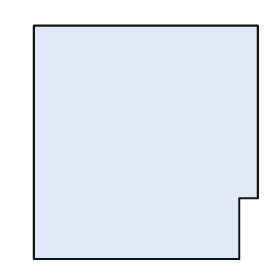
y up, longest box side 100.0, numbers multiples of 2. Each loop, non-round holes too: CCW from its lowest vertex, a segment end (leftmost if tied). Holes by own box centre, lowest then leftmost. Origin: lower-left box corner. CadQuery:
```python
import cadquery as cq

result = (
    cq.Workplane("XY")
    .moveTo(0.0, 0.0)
    .lineTo(88.0, 0.0)
    .lineTo(88.0, 26.0)
    .lineTo(96.0, 26.0)
    .lineTo(96.0, 100.0)
    .lineTo(0.0, 100.0)
    .close()
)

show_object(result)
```